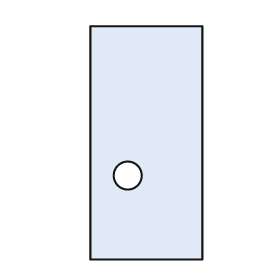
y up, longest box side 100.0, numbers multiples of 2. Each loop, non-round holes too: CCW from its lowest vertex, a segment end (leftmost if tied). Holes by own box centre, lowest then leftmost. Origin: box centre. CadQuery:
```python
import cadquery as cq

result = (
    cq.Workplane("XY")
    .moveTo(-24.0, -50.0)
    .lineTo(24.0, -50.0)
    .lineTo(24.0, 50.0)
    .lineTo(-24.0, 50.0)
    .close()
    .moveTo(-8.0, -14.0)
    .circle(6.0)
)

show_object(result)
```